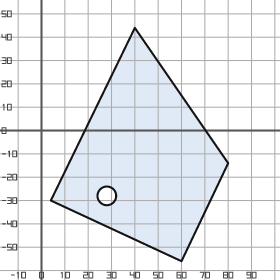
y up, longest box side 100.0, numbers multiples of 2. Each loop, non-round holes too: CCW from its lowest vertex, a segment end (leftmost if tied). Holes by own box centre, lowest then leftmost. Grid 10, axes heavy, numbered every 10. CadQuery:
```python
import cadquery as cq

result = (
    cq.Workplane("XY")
    .moveTo(60.0, -56.0)
    .lineTo(80.0, -14.0)
    .lineTo(40.0, 44.0)
    .lineTo(4.0, -30.0)
    .close()
    .moveTo(28.0, -28.0)
    .circle(4.0)
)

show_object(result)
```